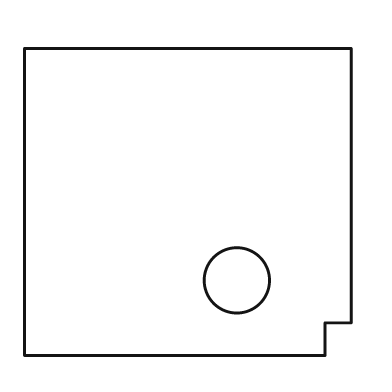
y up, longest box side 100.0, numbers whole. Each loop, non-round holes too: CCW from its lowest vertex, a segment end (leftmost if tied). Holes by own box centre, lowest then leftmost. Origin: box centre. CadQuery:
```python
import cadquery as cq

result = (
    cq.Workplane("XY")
    .moveTo(-50.0, -47.0)
    .lineTo(42.0, -47.0)
    .lineTo(42.0, -37.0)
    .lineTo(50.0, -37.0)
    .lineTo(50.0, 47.0)
    .lineTo(-50.0, 47.0)
    .close()
    .moveTo(15.0, -24.0)
    .circle(10.0)
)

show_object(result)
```